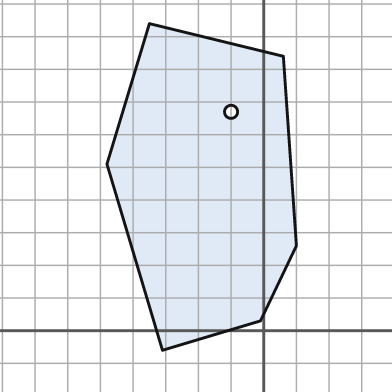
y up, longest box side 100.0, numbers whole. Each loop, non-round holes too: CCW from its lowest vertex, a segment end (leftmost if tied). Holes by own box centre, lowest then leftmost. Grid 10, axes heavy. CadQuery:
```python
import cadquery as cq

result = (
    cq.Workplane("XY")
    .moveTo(-31.0, -6.0)
    .lineTo(-1.0, 3.0)
    .lineTo(10.0, 26.0)
    .lineTo(6.0, 84.0)
    .lineTo(-35.0, 94.0)
    .lineTo(-48.0, 51.0)
    .close()
    .moveTo(-10.0, 67.0)
    .circle(2.0)
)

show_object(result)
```